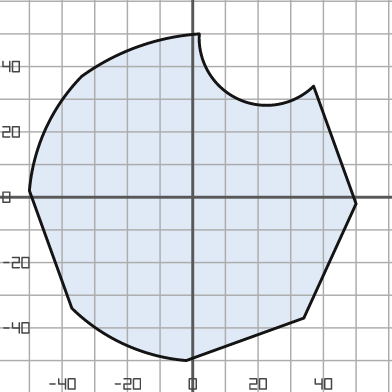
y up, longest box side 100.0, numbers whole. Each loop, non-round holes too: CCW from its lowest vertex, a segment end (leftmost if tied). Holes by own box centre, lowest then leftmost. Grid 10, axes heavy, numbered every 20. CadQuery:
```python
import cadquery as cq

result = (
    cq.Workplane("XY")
    .moveTo(-2.0, -50.0)
    .lineTo(34.0, -37.0)
    .lineTo(50.0, -2.0)
    .lineTo(37.0, 34.0)
    .threePointArc((14.0, 30.0), (2.0, 50.0))
    .threePointArc((-17.0, 46.0), (-34.0, 37.0))
    .threePointArc((-45.0, 21.0), (-50.0, 2.0))
    .lineTo(-37.0, -34.0)
    .threePointArc((-21.0, -45.0), (-2.0, -50.0))
    .close()
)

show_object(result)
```